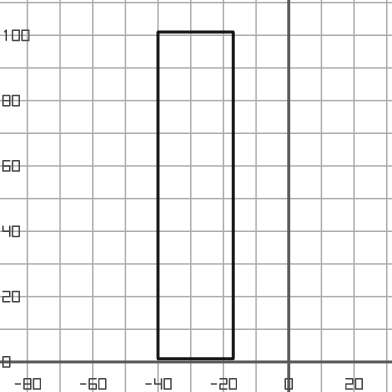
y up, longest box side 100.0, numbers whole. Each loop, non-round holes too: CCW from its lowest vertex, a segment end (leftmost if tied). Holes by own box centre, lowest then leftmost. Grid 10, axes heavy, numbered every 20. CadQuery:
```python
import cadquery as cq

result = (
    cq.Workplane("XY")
    .moveTo(-40.0, 1.0)
    .lineTo(-17.0, 1.0)
    .lineTo(-17.0, 101.0)
    .lineTo(-40.0, 101.0)
    .close()
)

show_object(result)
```